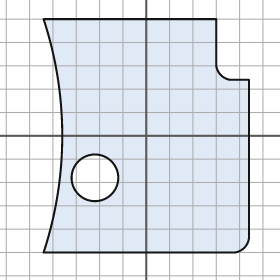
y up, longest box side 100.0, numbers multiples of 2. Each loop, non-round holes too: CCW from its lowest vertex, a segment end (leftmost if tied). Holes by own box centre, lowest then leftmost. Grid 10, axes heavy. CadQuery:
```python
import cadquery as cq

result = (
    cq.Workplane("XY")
    .moveTo(-44.0, -50.0)
    .lineTo(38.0, -50.0)
    .threePointArc((42.0, -48.0), (44.0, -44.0))
    .lineTo(44.0, 24.0)
    .lineTo(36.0, 24.0)
    .threePointArc((32.0, 26.0), (30.0, 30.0))
    .lineTo(30.0, 50.0)
    .lineTo(-44.0, 50.0)
    .threePointArc((-36.0, 0.0), (-44.0, -50.0))
    .close()
    .moveTo(-22.0, -18.0)
    .circle(10.0)
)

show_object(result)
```